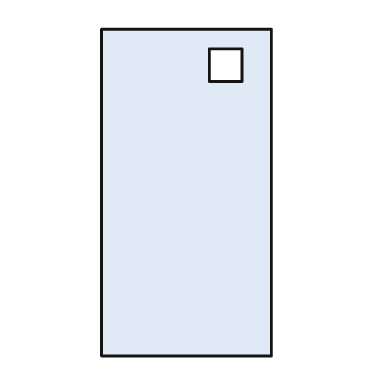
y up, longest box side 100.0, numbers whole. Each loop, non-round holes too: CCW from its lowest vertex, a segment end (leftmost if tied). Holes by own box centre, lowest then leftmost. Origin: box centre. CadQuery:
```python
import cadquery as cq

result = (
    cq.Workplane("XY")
    .moveTo(-26.0, -50.0)
    .lineTo(26.0, -50.0)
    .lineTo(26.0, 50.0)
    .lineTo(-26.0, 50.0)
    .close()
    .moveTo(7.0, 34.0)
    .lineTo(17.0, 34.0)
    .lineTo(17.0, 44.0)
    .lineTo(7.0, 44.0)
    .close()
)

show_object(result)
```